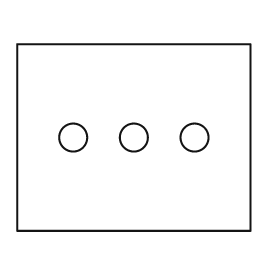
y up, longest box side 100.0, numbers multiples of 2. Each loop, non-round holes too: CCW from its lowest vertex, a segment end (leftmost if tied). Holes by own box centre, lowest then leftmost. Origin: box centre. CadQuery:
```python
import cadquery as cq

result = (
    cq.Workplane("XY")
    .moveTo(-50.0, -40.0)
    .lineTo(50.0, -40.0)
    .lineTo(50.0, 40.0)
    .lineTo(-50.0, 40.0)
    .close()
    .moveTo(-26.0, 0.0)
    .circle(6.0)
    .moveTo(0.0, 0.0)
    .circle(6.0)
    .moveTo(26.0, 0.0)
    .circle(6.0)
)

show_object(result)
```